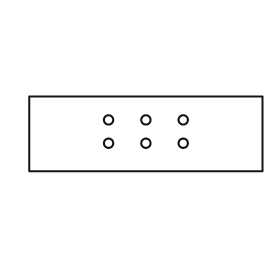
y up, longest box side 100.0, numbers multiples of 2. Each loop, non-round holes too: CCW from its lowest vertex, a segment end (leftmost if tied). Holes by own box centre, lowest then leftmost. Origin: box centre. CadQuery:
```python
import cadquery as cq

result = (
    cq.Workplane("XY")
    .moveTo(-50.0, -16.0)
    .lineTo(50.0, -16.0)
    .lineTo(50.0, 16.0)
    .lineTo(-50.0, 16.0)
    .close()
    .moveTo(-16.0, -4.0)
    .circle(2.0)
    .moveTo(0.0, -4.0)
    .circle(2.0)
    .moveTo(16.0, -4.0)
    .circle(2.0)
    .moveTo(-16.0, 6.0)
    .circle(2.0)
    .moveTo(0.0, 6.0)
    .circle(2.0)
    .moveTo(16.0, 6.0)
    .circle(2.0)
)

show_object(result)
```